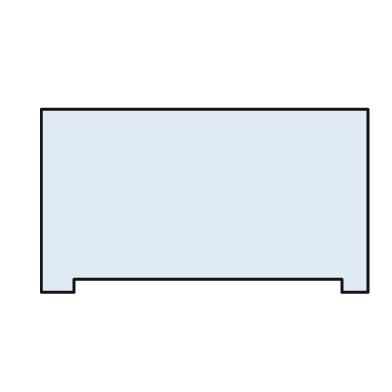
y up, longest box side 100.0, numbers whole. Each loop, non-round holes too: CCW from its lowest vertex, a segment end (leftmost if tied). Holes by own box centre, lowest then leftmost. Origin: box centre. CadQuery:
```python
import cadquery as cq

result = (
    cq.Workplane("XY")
    .moveTo(-50.0, -28.0)
    .lineTo(-40.0, -28.0)
    .lineTo(-40.0, -24.0)
    .lineTo(42.0, -24.0)
    .lineTo(42.0, -28.0)
    .lineTo(50.0, -28.0)
    .lineTo(50.0, 28.0)
    .lineTo(-50.0, 28.0)
    .close()
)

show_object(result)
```